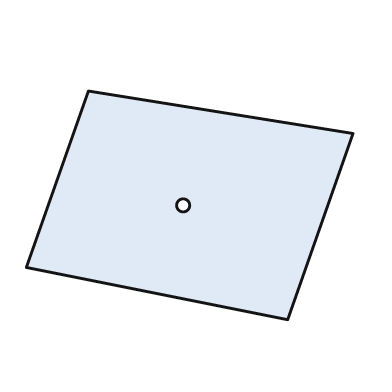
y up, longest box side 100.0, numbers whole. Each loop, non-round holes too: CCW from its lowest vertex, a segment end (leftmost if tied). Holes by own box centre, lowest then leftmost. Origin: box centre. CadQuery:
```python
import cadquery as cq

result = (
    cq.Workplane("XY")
    .moveTo(30.0, -35.0)
    .lineTo(50.0, 22.0)
    .lineTo(-31.0, 35.0)
    .lineTo(-50.0, -19.0)
    .close()
    .moveTo(-2.0, 0.0)
    .circle(2.0)
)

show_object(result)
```